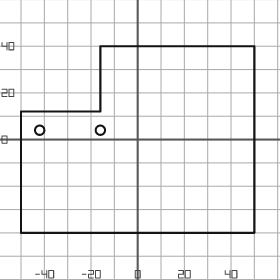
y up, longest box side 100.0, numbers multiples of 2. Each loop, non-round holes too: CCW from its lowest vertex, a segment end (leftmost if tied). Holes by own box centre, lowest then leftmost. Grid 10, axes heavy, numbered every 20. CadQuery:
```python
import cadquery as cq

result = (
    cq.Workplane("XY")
    .moveTo(-50.0, -40.0)
    .lineTo(50.0, -40.0)
    .lineTo(50.0, 40.0)
    .lineTo(-16.0, 40.0)
    .lineTo(-16.0, 12.0)
    .lineTo(-50.0, 12.0)
    .close()
    .moveTo(-42.0, 4.0)
    .circle(2.0)
    .moveTo(-16.0, 4.0)
    .circle(2.0)
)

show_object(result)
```